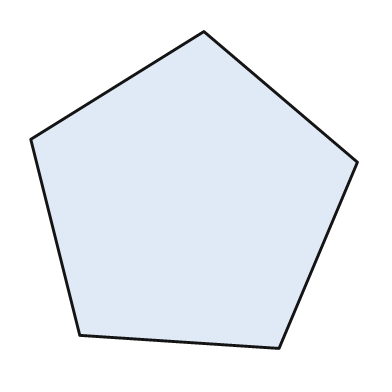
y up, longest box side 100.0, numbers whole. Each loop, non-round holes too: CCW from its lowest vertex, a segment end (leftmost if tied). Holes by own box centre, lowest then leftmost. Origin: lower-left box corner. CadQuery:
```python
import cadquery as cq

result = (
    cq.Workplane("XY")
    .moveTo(76.0, 0.0)
    .lineTo(100.0, 57.0)
    .lineTo(53.0, 97.0)
    .lineTo(0.0, 64.0)
    .lineTo(15.0, 4.0)
    .close()
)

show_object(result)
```